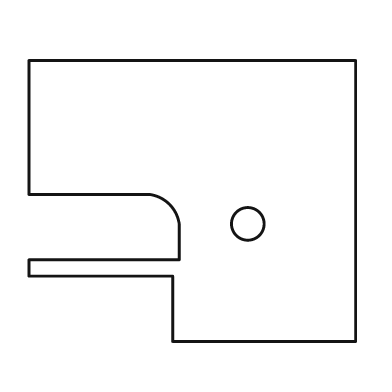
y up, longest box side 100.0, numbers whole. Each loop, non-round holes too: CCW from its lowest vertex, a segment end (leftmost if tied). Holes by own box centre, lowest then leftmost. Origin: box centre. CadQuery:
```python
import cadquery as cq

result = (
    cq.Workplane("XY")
    .moveTo(-6.0, -43.0)
    .lineTo(50.0, -43.0)
    .lineTo(50.0, 43.0)
    .lineTo(-50.0, 43.0)
    .lineTo(-50.0, 2.0)
    .lineTo(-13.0, 2.0)
    .threePointArc((-7.0, -1.0), (-4.0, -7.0))
    .lineTo(-4.0, -18.0)
    .lineTo(-50.0, -18.0)
    .lineTo(-50.0, -23.0)
    .lineTo(-6.0, -23.0)
    .close()
    .moveTo(17.0, -7.0)
    .circle(5.0)
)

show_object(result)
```